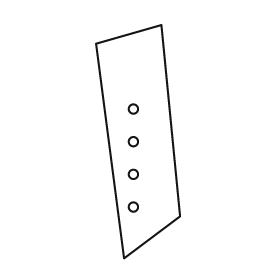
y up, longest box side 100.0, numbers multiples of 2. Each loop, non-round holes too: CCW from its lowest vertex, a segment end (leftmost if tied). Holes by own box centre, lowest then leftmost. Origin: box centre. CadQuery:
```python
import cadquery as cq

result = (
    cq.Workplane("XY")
    .moveTo(-6.0, -50.0)
    .lineTo(18.0, -32.0)
    .lineTo(10.0, 50.0)
    .lineTo(-18.0, 42.0)
    .close()
    .moveTo(-2.0, -28.0)
    .circle(2.0)
    .moveTo(-2.0, -14.0)
    .circle(2.0)
    .moveTo(-2.0, 0.0)
    .circle(2.0)
    .moveTo(-2.0, 14.0)
    .circle(2.0)
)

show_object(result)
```